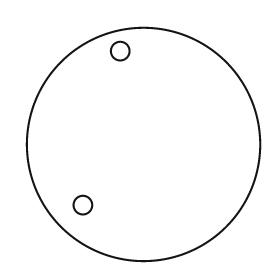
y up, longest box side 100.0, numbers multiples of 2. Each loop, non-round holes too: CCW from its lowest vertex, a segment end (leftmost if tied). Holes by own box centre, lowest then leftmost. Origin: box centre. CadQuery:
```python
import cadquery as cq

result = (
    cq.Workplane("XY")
    .moveTo(0.0, 0.0)
    .circle(50.0)
    .moveTo(-26.0, -26.0)
    .circle(4.0)
    .moveTo(-10.0, 40.0)
    .circle(4.0)
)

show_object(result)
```